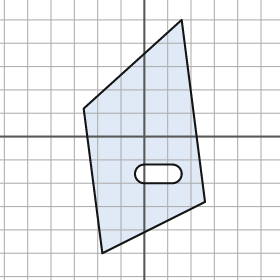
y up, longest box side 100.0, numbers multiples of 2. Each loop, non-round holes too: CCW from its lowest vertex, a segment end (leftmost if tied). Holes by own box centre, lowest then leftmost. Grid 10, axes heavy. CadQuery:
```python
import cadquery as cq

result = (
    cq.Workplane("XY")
    .moveTo(-18.0, -50.0)
    .lineTo(26.0, -28.0)
    .lineTo(16.0, 50.0)
    .lineTo(-26.0, 12.0)
    .close()
    .moveTo(0.0, -20.0)
    .lineTo(12.0, -20.0)
    .threePointArc((16.0, -16.0), (12.0, -12.0))
    .lineTo(0.0, -12.0)
    .threePointArc((-4.0, -16.0), (0.0, -20.0))
    .close()
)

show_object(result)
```